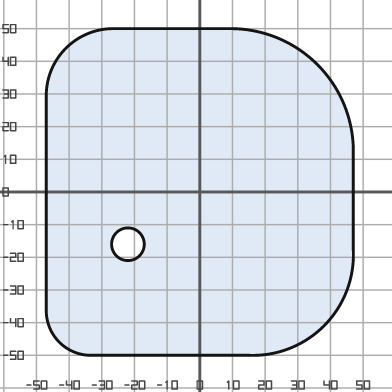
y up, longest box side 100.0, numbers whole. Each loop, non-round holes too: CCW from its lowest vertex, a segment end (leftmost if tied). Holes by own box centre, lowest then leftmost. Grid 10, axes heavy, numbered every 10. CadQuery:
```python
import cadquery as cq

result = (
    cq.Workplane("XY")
    .moveTo(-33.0, -50.0)
    .lineTo(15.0, -50.0)
    .threePointArc((38.0, -41.0), (47.0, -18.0))
    .lineTo(47.0, 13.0)
    .threePointArc((36.0, 39.0), (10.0, 50.0))
    .lineTo(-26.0, 50.0)
    .threePointArc((-41.0, 44.0), (-47.0, 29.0))
    .lineTo(-47.0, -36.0)
    .threePointArc((-43.0, -46.0), (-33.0, -50.0))
    .close()
    .moveTo(-22.0, -16.0)
    .circle(5.0)
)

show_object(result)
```